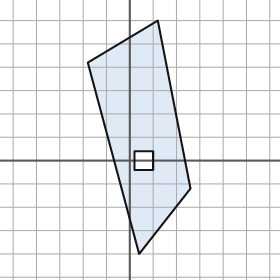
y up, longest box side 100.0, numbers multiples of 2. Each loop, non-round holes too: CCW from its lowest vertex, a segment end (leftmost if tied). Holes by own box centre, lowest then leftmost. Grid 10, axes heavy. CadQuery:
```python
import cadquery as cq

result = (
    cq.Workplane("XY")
    .moveTo(4.0, -40.0)
    .lineTo(26.0, -12.0)
    .lineTo(12.0, 60.0)
    .lineTo(-18.0, 42.0)
    .close()
    .moveTo(2.0, -4.0)
    .lineTo(10.0, -4.0)
    .lineTo(10.0, 4.0)
    .lineTo(2.0, 4.0)
    .close()
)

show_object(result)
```